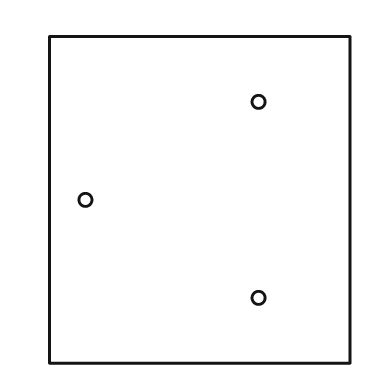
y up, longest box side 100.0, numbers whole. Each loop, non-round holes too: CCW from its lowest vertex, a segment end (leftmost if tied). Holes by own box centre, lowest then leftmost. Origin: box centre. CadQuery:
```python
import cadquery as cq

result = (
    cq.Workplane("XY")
    .moveTo(-46.0, -50.0)
    .lineTo(46.0, -50.0)
    .lineTo(46.0, 50.0)
    .lineTo(-46.0, 50.0)
    .close()
    .moveTo(18.0, -30.0)
    .circle(2.0)
    .moveTo(-35.0, 0.0)
    .circle(2.0)
    .moveTo(18.0, 30.0)
    .circle(2.0)
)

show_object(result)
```